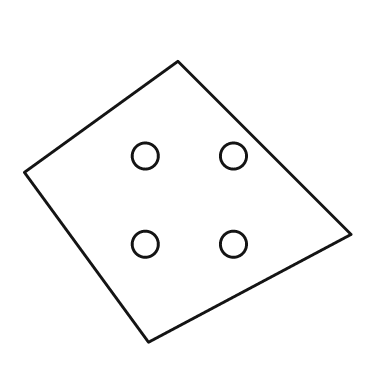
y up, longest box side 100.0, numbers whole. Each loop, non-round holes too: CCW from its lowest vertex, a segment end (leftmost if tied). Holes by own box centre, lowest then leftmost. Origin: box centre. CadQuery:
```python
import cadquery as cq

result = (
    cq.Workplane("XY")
    .moveTo(-12.0, -43.0)
    .lineTo(50.0, -10.0)
    .lineTo(-3.0, 43.0)
    .lineTo(-50.0, 9.0)
    .close()
    .moveTo(-13.0, -13.0)
    .circle(4.0)
    .moveTo(14.0, -13.0)
    .circle(4.0)
    .moveTo(-13.0, 14.0)
    .circle(4.0)
    .moveTo(14.0, 14.0)
    .circle(4.0)
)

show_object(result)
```